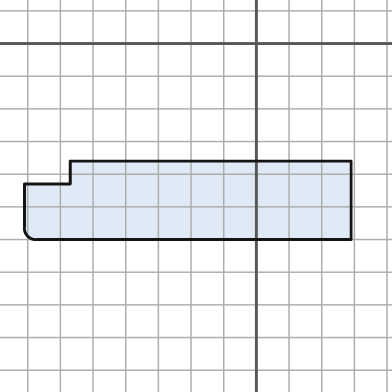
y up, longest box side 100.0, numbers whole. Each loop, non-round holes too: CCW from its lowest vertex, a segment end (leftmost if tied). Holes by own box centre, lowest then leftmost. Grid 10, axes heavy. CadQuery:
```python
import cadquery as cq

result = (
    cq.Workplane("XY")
    .moveTo(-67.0, -60.0)
    .lineTo(29.0, -60.0)
    .lineTo(29.0, -36.0)
    .lineTo(-57.0, -36.0)
    .lineTo(-57.0, -43.0)
    .lineTo(-71.0, -43.0)
    .lineTo(-71.0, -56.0)
    .threePointArc((-70.0, -59.0), (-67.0, -60.0))
    .close()
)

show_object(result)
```